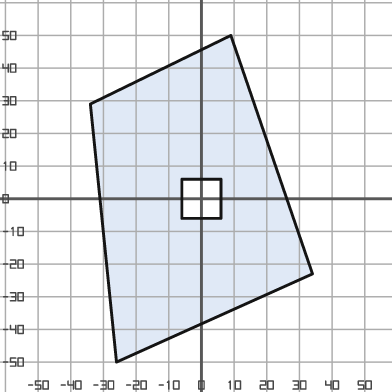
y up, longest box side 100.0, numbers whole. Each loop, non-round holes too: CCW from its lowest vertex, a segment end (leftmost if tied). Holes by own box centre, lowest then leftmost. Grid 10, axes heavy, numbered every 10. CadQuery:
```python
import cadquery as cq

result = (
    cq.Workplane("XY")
    .moveTo(-26.0, -50.0)
    .lineTo(34.0, -23.0)
    .lineTo(9.0, 50.0)
    .lineTo(-34.0, 29.0)
    .close()
    .moveTo(-6.0, -6.0)
    .lineTo(6.0, -6.0)
    .lineTo(6.0, 6.0)
    .lineTo(-6.0, 6.0)
    .close()
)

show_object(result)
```